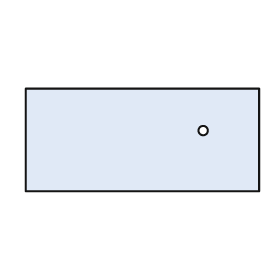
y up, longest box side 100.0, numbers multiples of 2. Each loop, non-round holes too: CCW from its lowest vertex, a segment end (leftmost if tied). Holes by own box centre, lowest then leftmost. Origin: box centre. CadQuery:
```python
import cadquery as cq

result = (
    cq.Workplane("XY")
    .moveTo(-50.0, -22.0)
    .lineTo(50.0, -22.0)
    .lineTo(50.0, 22.0)
    .lineTo(-50.0, 22.0)
    .close()
    .moveTo(26.0, 4.0)
    .circle(2.0)
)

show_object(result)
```